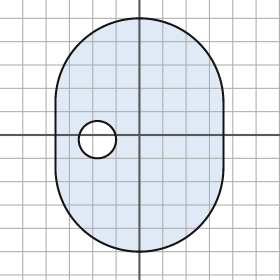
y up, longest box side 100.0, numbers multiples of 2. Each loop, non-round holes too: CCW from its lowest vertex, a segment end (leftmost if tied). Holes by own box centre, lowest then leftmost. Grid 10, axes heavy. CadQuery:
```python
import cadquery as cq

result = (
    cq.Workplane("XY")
    .moveTo(-36.0, -14.0)
    .threePointArc((0.0, -50.0), (36.0, -14.0))
    .lineTo(36.0, 14.0)
    .threePointArc((0.0, 50.0), (-36.0, 14.0))
    .close()
    .moveTo(-18.0, -2.0)
    .circle(8.0)
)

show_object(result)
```